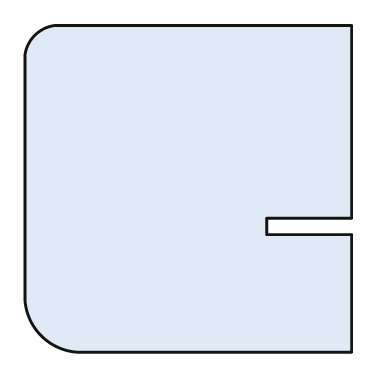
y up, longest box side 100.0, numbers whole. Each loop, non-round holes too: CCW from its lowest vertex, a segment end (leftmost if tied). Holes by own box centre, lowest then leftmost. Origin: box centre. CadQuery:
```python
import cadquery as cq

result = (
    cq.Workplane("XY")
    .moveTo(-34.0, -50.0)
    .lineTo(50.0, -50.0)
    .lineTo(50.0, -14.0)
    .lineTo(24.0, -14.0)
    .lineTo(24.0, -9.0)
    .lineTo(50.0, -9.0)
    .lineTo(50.0, 50.0)
    .lineTo(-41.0, 50.0)
    .threePointArc((-47.0, 47.0), (-50.0, 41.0))
    .lineTo(-50.0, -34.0)
    .threePointArc((-45.0, -45.0), (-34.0, -50.0))
    .close()
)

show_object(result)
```